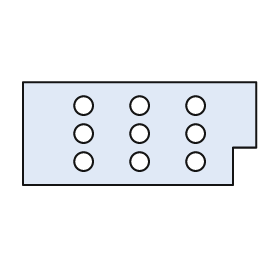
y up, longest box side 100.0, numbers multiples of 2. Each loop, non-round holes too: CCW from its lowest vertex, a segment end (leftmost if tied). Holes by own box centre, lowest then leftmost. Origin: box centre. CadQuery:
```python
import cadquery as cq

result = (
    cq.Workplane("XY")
    .moveTo(-50.0, -22.0)
    .lineTo(40.0, -22.0)
    .lineTo(40.0, -6.0)
    .lineTo(50.0, -6.0)
    .lineTo(50.0, 22.0)
    .lineTo(-50.0, 22.0)
    .close()
    .moveTo(-24.0, -12.0)
    .circle(4.0)
    .moveTo(0.0, -12.0)
    .circle(4.0)
    .moveTo(24.0, -12.0)
    .circle(4.0)
    .moveTo(-24.0, 0.0)
    .circle(4.0)
    .moveTo(0.0, 0.0)
    .circle(4.0)
    .moveTo(24.0, 0.0)
    .circle(4.0)
    .moveTo(-24.0, 12.0)
    .circle(4.0)
    .moveTo(0.0, 12.0)
    .circle(4.0)
    .moveTo(24.0, 12.0)
    .circle(4.0)
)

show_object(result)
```